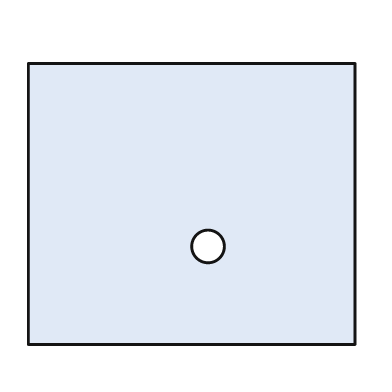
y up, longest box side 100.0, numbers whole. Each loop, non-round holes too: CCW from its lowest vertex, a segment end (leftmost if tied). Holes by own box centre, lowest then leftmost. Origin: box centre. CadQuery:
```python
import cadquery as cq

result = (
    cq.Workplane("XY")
    .moveTo(-50.0, -43.0)
    .lineTo(50.0, -43.0)
    .lineTo(50.0, 43.0)
    .lineTo(-50.0, 43.0)
    .close()
    .moveTo(5.0, -13.0)
    .circle(5.0)
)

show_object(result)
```